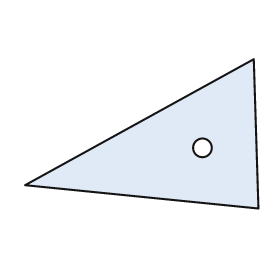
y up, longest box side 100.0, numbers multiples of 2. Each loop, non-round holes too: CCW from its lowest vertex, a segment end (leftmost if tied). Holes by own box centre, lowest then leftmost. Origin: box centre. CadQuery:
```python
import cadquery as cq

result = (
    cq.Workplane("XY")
    .moveTo(50.0, -32.0)
    .lineTo(48.0, 32.0)
    .lineTo(-50.0, -22.0)
    .close()
    .moveTo(26.0, -6.0)
    .circle(4.0)
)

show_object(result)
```